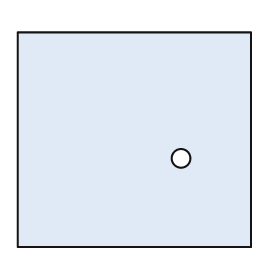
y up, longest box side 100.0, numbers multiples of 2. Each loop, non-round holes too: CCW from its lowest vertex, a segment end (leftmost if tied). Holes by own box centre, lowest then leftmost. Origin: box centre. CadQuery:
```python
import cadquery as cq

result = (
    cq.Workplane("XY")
    .moveTo(-50.0, -46.0)
    .lineTo(50.0, -46.0)
    .lineTo(50.0, 46.0)
    .lineTo(-50.0, 46.0)
    .close()
    .moveTo(20.0, -8.0)
    .circle(4.0)
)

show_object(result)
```